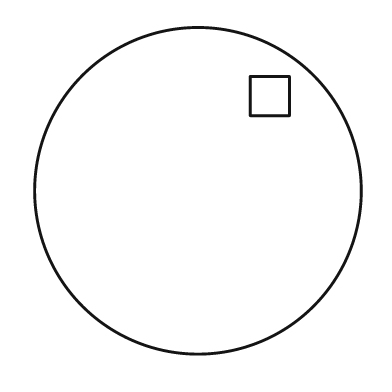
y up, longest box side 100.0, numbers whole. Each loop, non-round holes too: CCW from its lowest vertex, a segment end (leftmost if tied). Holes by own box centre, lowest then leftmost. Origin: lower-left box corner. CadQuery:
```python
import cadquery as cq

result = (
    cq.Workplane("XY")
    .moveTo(50.0, 50.0)
    .circle(50.0)
    .moveTo(66.0, 73.0)
    .lineTo(78.0, 73.0)
    .lineTo(78.0, 85.0)
    .lineTo(66.0, 85.0)
    .close()
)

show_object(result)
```